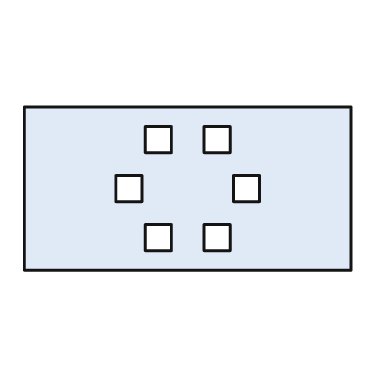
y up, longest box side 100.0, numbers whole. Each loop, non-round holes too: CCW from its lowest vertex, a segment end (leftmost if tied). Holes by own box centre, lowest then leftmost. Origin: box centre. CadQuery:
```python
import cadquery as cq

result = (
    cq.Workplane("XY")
    .moveTo(-50.0, -25.0)
    .lineTo(50.0, -25.0)
    .lineTo(50.0, 25.0)
    .lineTo(-50.0, 25.0)
    .close()
    .moveTo(-13.0, -19.0)
    .lineTo(-5.0, -19.0)
    .lineTo(-5.0, -11.0)
    .lineTo(-13.0, -11.0)
    .close()
    .moveTo(5.0, -19.0)
    .lineTo(13.0, -19.0)
    .lineTo(13.0, -11.0)
    .lineTo(5.0, -11.0)
    .close()
    .moveTo(-22.0, -4.0)
    .lineTo(-14.0, -4.0)
    .lineTo(-14.0, 4.0)
    .lineTo(-22.0, 4.0)
    .close()
    .moveTo(14.0, -4.0)
    .lineTo(22.0, -4.0)
    .lineTo(22.0, 4.0)
    .lineTo(14.0, 4.0)
    .close()
    .moveTo(-13.0, 11.0)
    .lineTo(-5.0, 11.0)
    .lineTo(-5.0, 19.0)
    .lineTo(-13.0, 19.0)
    .close()
    .moveTo(5.0, 11.0)
    .lineTo(13.0, 11.0)
    .lineTo(13.0, 19.0)
    .lineTo(5.0, 19.0)
    .close()
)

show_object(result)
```